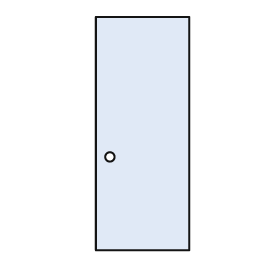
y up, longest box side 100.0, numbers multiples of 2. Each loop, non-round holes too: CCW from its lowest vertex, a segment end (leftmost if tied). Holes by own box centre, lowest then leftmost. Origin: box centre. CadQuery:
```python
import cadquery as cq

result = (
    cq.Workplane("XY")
    .moveTo(-20.0, -50.0)
    .lineTo(20.0, -50.0)
    .lineTo(20.0, 50.0)
    .lineTo(-20.0, 50.0)
    .close()
    .moveTo(-14.0, -10.0)
    .circle(2.0)
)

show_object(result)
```